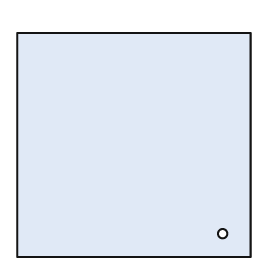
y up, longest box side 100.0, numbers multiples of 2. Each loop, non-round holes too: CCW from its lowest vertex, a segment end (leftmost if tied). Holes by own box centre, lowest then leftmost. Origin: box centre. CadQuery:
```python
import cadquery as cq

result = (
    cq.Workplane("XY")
    .moveTo(-50.0, -48.0)
    .lineTo(50.0, -48.0)
    .lineTo(50.0, 48.0)
    .lineTo(-50.0, 48.0)
    .close()
    .moveTo(38.0, -38.0)
    .circle(2.0)
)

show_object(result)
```